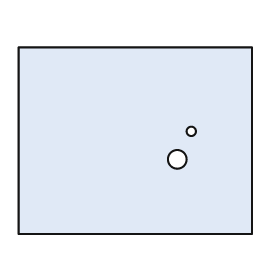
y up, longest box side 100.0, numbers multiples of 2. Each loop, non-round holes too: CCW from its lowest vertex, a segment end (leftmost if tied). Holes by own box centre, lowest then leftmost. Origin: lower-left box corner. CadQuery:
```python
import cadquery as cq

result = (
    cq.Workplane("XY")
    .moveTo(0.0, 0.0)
    .lineTo(100.0, 0.0)
    .lineTo(100.0, 80.0)
    .lineTo(0.0, 80.0)
    .close()
    .moveTo(68.0, 32.0)
    .circle(4.0)
    .moveTo(74.0, 44.0)
    .circle(2.0)
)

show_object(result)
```